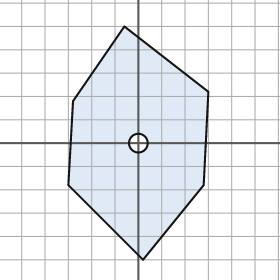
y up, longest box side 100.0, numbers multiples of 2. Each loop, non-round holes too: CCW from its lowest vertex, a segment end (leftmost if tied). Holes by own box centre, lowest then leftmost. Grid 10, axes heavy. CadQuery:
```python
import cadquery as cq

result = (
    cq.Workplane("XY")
    .moveTo(2.0, -50.0)
    .lineTo(28.0, -18.0)
    .lineTo(30.0, 22.0)
    .lineTo(-6.0, 50.0)
    .lineTo(-28.0, 18.0)
    .lineTo(-30.0, -18.0)
    .close()
    .moveTo(0.0, 0.0)
    .circle(4.0)
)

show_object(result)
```